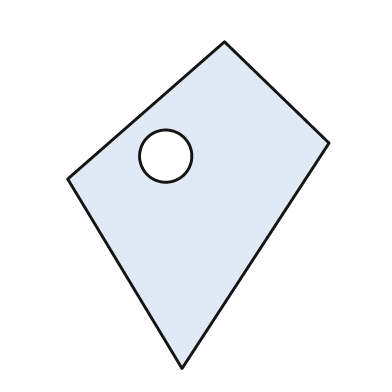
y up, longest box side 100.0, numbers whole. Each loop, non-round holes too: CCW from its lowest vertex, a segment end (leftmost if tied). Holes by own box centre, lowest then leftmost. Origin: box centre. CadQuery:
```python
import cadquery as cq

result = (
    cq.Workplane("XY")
    .moveTo(-5.0, -50.0)
    .lineTo(40.0, 19.0)
    .lineTo(8.0, 50.0)
    .lineTo(-40.0, 8.0)
    .close()
    .moveTo(-10.0, 15.0)
    .circle(8.0)
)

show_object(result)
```